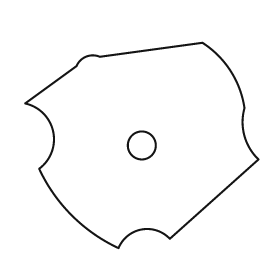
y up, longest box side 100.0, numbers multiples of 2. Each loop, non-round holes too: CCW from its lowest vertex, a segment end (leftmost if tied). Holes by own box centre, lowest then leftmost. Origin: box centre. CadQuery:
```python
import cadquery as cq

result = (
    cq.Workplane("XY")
    .moveTo(-10.0, -44.0)
    .threePointArc((0.0, -36.0), (12.0, -40.0))
    .lineTo(50.0, -6.0)
    .threePointArc((44.0, 4.0), (44.0, 16.0))
    .threePointArc((38.0, 32.0), (26.0, 44.0))
    .lineTo(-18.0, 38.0)
    .threePointArc((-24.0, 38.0), (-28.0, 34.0))
    .lineTo(-50.0, 18.0)
    .threePointArc((-38.0, 6.0), (-44.0, -10.0))
    .threePointArc((-30.0, -30.0), (-10.0, -44.0))
    .close()
    .moveTo(0.0, 0.0)
    .circle(6.0)
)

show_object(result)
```